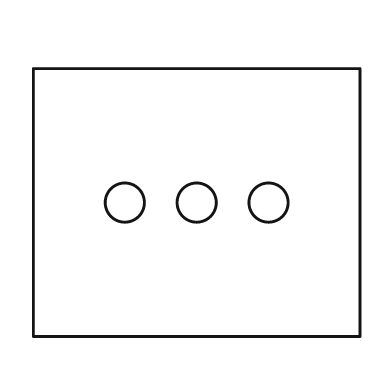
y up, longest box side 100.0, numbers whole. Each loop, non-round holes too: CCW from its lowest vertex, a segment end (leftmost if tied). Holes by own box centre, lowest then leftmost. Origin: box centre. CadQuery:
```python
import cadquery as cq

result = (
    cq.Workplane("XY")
    .moveTo(-50.0, -41.0)
    .lineTo(50.0, -41.0)
    .lineTo(50.0, 41.0)
    .lineTo(-50.0, 41.0)
    .close()
    .moveTo(-22.0, 0.0)
    .circle(6.0)
    .moveTo(0.0, 0.0)
    .circle(6.0)
    .moveTo(22.0, 0.0)
    .circle(6.0)
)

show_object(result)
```